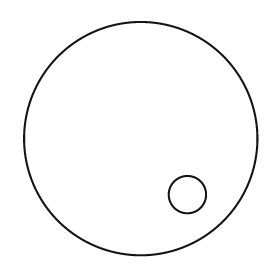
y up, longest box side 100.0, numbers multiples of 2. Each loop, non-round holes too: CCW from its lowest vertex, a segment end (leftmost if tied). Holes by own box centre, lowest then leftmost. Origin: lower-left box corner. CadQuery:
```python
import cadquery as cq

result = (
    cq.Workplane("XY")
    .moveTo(50.0, 50.0)
    .circle(50.0)
    .moveTo(70.0, 26.0)
    .circle(8.0)
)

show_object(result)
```